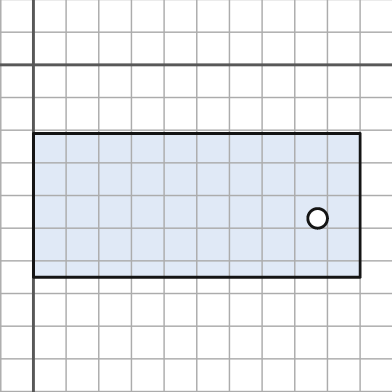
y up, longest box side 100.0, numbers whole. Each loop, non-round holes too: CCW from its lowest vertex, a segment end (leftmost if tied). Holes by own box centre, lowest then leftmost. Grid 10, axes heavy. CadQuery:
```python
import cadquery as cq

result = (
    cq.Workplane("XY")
    .moveTo(0.0, -65.0)
    .lineTo(100.0, -65.0)
    .lineTo(100.0, -21.0)
    .lineTo(0.0, -21.0)
    .close()
    .moveTo(87.0, -47.0)
    .circle(3.0)
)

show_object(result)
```